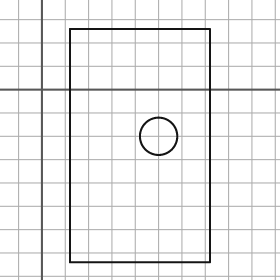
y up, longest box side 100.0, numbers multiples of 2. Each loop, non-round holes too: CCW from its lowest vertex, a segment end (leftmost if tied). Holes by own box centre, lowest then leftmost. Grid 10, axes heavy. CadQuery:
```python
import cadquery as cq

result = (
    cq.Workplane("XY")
    .moveTo(12.0, -74.0)
    .lineTo(72.0, -74.0)
    .lineTo(72.0, 26.0)
    .lineTo(12.0, 26.0)
    .close()
    .moveTo(50.0, -20.0)
    .circle(8.0)
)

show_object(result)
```